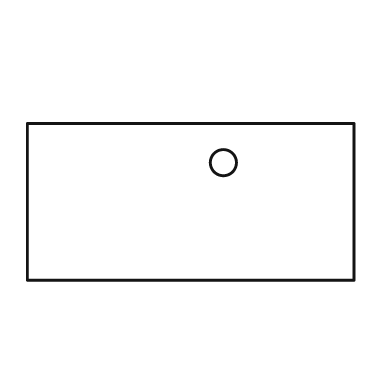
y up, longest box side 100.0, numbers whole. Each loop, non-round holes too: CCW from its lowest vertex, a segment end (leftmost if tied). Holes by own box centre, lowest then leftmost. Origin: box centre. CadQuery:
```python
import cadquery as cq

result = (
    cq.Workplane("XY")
    .moveTo(-50.0, -24.0)
    .lineTo(50.0, -24.0)
    .lineTo(50.0, 24.0)
    .lineTo(-50.0, 24.0)
    .close()
    .moveTo(10.0, 12.0)
    .circle(4.0)
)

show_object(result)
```